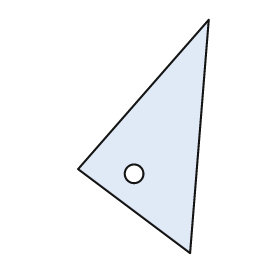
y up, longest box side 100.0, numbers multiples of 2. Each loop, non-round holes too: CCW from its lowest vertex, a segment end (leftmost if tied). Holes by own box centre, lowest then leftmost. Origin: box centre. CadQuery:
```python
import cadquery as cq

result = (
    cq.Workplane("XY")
    .moveTo(20.0, -50.0)
    .lineTo(28.0, 50.0)
    .lineTo(-28.0, -14.0)
    .close()
    .moveTo(-4.0, -16.0)
    .circle(4.0)
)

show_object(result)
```